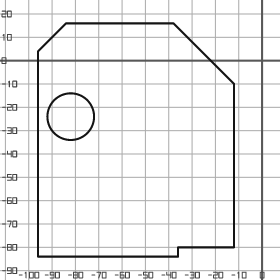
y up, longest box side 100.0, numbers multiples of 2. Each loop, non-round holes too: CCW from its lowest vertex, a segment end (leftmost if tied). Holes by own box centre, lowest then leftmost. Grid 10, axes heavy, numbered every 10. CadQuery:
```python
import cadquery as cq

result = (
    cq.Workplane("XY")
    .moveTo(-96.0, -84.0)
    .lineTo(-36.0, -84.0)
    .lineTo(-36.0, -80.0)
    .lineTo(-12.0, -80.0)
    .lineTo(-12.0, -10.0)
    .lineTo(-38.0, 16.0)
    .lineTo(-84.0, 16.0)
    .lineTo(-96.0, 4.0)
    .close()
    .moveTo(-82.0, -24.0)
    .circle(10.0)
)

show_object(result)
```